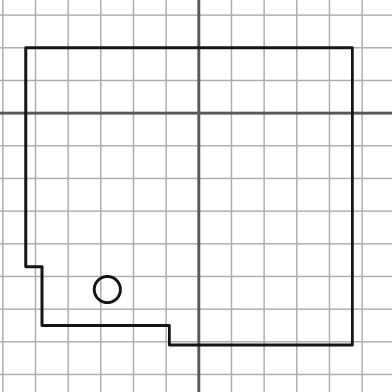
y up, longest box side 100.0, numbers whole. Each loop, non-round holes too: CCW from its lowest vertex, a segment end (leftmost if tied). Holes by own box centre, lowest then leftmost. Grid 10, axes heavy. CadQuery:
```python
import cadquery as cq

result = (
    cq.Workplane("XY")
    .moveTo(-9.0, -71.0)
    .lineTo(47.0, -71.0)
    .lineTo(47.0, 20.0)
    .lineTo(-53.0, 20.0)
    .lineTo(-53.0, -47.0)
    .lineTo(-48.0, -47.0)
    .lineTo(-48.0, -65.0)
    .lineTo(-9.0, -65.0)
    .close()
    .moveTo(-28.0, -54.0)
    .circle(4.0)
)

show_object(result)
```